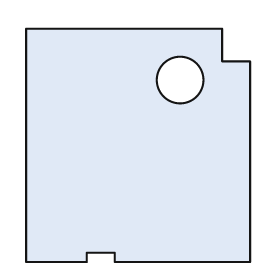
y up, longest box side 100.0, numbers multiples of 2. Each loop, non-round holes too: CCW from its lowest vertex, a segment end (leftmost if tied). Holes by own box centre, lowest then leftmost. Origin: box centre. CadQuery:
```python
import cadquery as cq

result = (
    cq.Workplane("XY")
    .moveTo(-48.0, -50.0)
    .lineTo(-22.0, -50.0)
    .lineTo(-22.0, -46.0)
    .lineTo(-10.0, -46.0)
    .lineTo(-10.0, -50.0)
    .lineTo(48.0, -50.0)
    .lineTo(48.0, 36.0)
    .lineTo(36.0, 36.0)
    .lineTo(36.0, 50.0)
    .lineTo(-48.0, 50.0)
    .close()
    .moveTo(18.0, 28.0)
    .circle(10.0)
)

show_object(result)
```